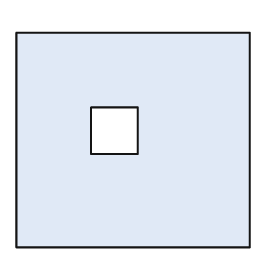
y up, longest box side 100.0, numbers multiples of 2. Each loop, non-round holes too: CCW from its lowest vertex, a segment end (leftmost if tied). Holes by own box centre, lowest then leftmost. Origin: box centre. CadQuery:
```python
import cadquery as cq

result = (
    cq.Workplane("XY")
    .moveTo(-50.0, -46.0)
    .lineTo(50.0, -46.0)
    .lineTo(50.0, 46.0)
    .lineTo(-50.0, 46.0)
    .close()
    .moveTo(-18.0, -6.0)
    .lineTo(2.0, -6.0)
    .lineTo(2.0, 14.0)
    .lineTo(-18.0, 14.0)
    .close()
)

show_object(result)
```